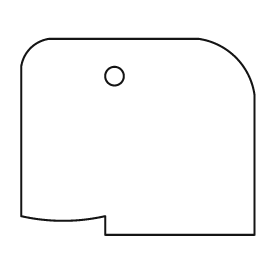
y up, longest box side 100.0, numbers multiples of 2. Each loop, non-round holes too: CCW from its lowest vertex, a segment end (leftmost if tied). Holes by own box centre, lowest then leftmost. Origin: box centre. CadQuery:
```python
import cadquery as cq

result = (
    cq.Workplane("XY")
    .moveTo(-14.0, -42.0)
    .lineTo(50.0, -42.0)
    .lineTo(50.0, 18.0)
    .threePointArc((42.0, 34.0), (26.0, 42.0))
    .lineTo(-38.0, 42.0)
    .threePointArc((-46.0, 38.0), (-50.0, 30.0))
    .lineTo(-50.0, -34.0)
    .threePointArc((-32.0, -36.0), (-14.0, -34.0))
    .close()
    .moveTo(-10.0, 26.0)
    .circle(4.0)
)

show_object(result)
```